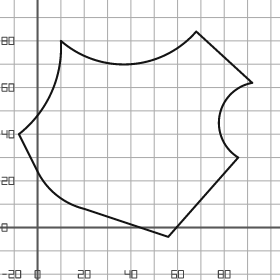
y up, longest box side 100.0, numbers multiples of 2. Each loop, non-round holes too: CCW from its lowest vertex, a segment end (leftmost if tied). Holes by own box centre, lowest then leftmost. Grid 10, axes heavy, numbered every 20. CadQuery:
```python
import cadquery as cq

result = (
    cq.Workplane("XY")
    .moveTo(56.0, -4.0)
    .lineTo(86.0, 30.0)
    .threePointArc((78.0, 48.0), (92.0, 62.0))
    .lineTo(68.0, 84.0)
    .threePointArc((40.0, 70.0), (10.0, 80.0))
    .threePointArc((6.0, 58.0), (-8.0, 40.0))
    .lineTo(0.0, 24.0)
    .threePointArc((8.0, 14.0), (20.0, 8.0))
    .close()
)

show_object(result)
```